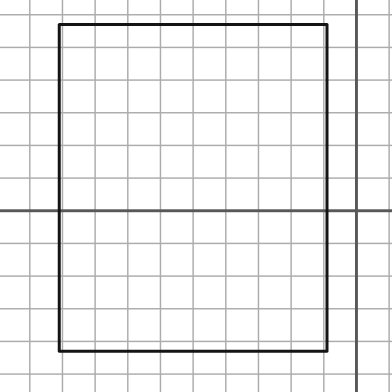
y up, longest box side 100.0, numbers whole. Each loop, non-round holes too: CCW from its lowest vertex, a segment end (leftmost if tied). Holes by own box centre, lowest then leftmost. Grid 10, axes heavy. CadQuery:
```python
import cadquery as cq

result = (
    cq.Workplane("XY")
    .moveTo(-91.0, -43.0)
    .lineTo(-9.0, -43.0)
    .lineTo(-9.0, 57.0)
    .lineTo(-91.0, 57.0)
    .close()
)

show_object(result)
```